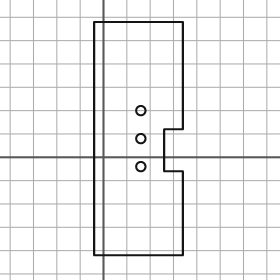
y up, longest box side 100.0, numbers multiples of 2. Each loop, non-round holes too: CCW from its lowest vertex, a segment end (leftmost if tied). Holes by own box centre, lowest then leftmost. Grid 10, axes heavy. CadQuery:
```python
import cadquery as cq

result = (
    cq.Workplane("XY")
    .moveTo(-4.0, -42.0)
    .lineTo(34.0, -42.0)
    .lineTo(34.0, -6.0)
    .lineTo(26.0, -6.0)
    .lineTo(26.0, 12.0)
    .lineTo(34.0, 12.0)
    .lineTo(34.0, 58.0)
    .lineTo(-4.0, 58.0)
    .close()
    .moveTo(16.0, -4.0)
    .circle(2.0)
    .moveTo(16.0, 8.0)
    .circle(2.0)
    .moveTo(16.0, 20.0)
    .circle(2.0)
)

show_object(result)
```